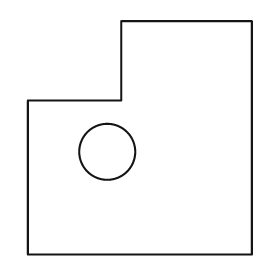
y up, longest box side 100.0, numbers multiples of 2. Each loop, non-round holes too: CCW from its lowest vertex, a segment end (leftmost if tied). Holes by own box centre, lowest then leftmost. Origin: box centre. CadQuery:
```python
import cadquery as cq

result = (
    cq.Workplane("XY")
    .moveTo(-48.0, -50.0)
    .lineTo(48.0, -50.0)
    .lineTo(48.0, 50.0)
    .lineTo(-8.0, 50.0)
    .lineTo(-8.0, 16.0)
    .lineTo(-48.0, 16.0)
    .close()
    .moveTo(-14.0, -6.0)
    .circle(12.0)
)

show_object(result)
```